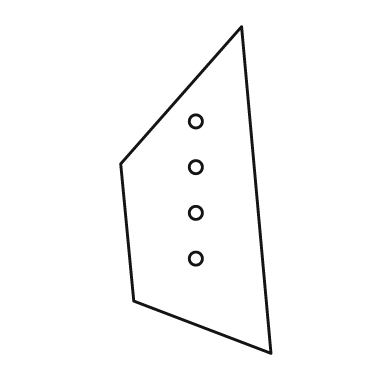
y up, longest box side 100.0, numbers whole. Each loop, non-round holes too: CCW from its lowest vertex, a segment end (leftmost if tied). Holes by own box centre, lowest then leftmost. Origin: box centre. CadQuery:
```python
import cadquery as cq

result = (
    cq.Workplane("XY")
    .moveTo(23.0, -50.0)
    .lineTo(14.0, 50.0)
    .lineTo(-23.0, 8.0)
    .lineTo(-19.0, -34.0)
    .close()
    .moveTo(0.0, -21.0)
    .circle(2.0)
    .moveTo(0.0, -7.0)
    .circle(2.0)
    .moveTo(0.0, 7.0)
    .circle(2.0)
    .moveTo(0.0, 21.0)
    .circle(2.0)
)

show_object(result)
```